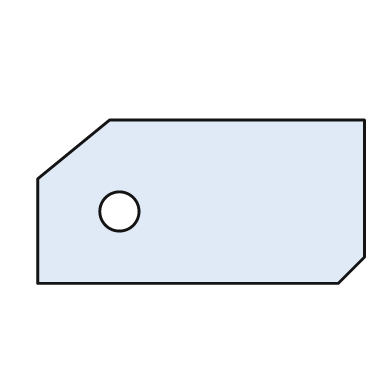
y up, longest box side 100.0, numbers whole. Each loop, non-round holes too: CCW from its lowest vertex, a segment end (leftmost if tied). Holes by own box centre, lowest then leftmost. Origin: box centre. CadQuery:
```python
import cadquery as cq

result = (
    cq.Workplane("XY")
    .moveTo(-50.0, -25.0)
    .lineTo(42.0, -25.0)
    .lineTo(50.0, -17.0)
    .lineTo(50.0, 25.0)
    .lineTo(-28.0, 25.0)
    .lineTo(-50.0, 7.0)
    .close()
    .moveTo(-25.0, -3.0)
    .circle(6.0)
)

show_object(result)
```